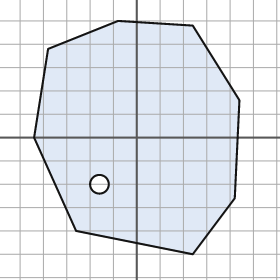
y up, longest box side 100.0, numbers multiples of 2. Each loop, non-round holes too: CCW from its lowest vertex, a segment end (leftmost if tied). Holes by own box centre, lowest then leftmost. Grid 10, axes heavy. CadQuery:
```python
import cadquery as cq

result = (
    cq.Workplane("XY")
    .moveTo(24.0, -50.0)
    .lineTo(42.0, -26.0)
    .lineTo(44.0, 16.0)
    .lineTo(24.0, 48.0)
    .lineTo(-8.0, 50.0)
    .lineTo(-38.0, 38.0)
    .lineTo(-44.0, 0.0)
    .lineTo(-26.0, -40.0)
    .close()
    .moveTo(-16.0, -20.0)
    .circle(4.0)
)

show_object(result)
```